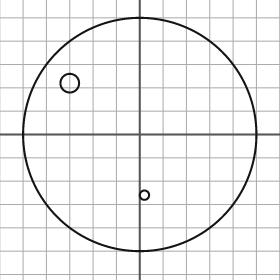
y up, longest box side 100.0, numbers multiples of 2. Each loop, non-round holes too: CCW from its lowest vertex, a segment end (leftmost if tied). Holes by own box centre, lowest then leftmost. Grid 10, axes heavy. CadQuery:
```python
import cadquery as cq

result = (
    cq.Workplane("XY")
    .moveTo(0.0, 0.0)
    .circle(50.0)
    .moveTo(2.0, -26.0)
    .circle(2.0)
    .moveTo(-30.0, 22.0)
    .circle(4.0)
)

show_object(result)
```